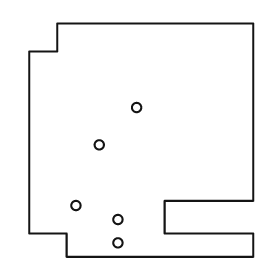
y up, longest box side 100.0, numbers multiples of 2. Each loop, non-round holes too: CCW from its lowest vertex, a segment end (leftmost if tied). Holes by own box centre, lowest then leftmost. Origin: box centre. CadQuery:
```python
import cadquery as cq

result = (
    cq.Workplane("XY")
    .moveTo(-32.0, -50.0)
    .lineTo(48.0, -50.0)
    .lineTo(48.0, -40.0)
    .lineTo(10.0, -40.0)
    .lineTo(10.0, -26.0)
    .lineTo(48.0, -26.0)
    .lineTo(48.0, 50.0)
    .lineTo(-36.0, 50.0)
    .lineTo(-36.0, 38.0)
    .lineTo(-48.0, 38.0)
    .lineTo(-48.0, -40.0)
    .lineTo(-32.0, -40.0)
    .close()
    .moveTo(-10.0, -44.0)
    .circle(2.0)
    .moveTo(-10.0, -34.0)
    .circle(2.0)
    .moveTo(-28.0, -28.0)
    .circle(2.0)
    .moveTo(-18.0, -2.0)
    .circle(2.0)
    .moveTo(-2.0, 14.0)
    .circle(2.0)
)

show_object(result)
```